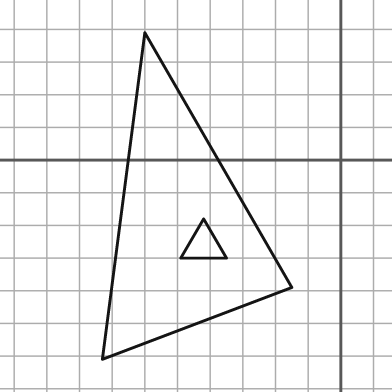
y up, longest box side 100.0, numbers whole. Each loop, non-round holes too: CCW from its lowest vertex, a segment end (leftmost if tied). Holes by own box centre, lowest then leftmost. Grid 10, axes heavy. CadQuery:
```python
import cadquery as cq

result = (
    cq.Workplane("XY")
    .moveTo(-73.0, -61.0)
    .lineTo(-15.0, -39.0)
    .lineTo(-60.0, 39.0)
    .close()
    .moveTo(-49.0, -30.0)
    .lineTo(-35.0, -30.0)
    .lineTo(-42.0, -18.0)
    .close()
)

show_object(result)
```